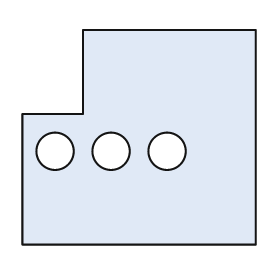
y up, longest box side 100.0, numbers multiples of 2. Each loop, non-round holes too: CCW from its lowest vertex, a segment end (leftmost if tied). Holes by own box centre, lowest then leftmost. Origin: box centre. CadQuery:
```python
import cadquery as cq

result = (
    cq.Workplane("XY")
    .moveTo(-50.0, -46.0)
    .lineTo(50.0, -46.0)
    .lineTo(50.0, 46.0)
    .lineTo(-24.0, 46.0)
    .lineTo(-24.0, 10.0)
    .lineTo(-50.0, 10.0)
    .close()
    .moveTo(-36.0, -6.0)
    .circle(8.0)
    .moveTo(-12.0, -6.0)
    .circle(8.0)
    .moveTo(12.0, -6.0)
    .circle(8.0)
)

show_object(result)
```